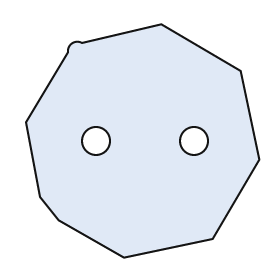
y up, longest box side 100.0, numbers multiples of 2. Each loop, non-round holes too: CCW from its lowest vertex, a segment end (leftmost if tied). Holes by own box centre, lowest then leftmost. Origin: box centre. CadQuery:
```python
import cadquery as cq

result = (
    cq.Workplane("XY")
    .moveTo(-8.0, -50.0)
    .lineTo(30.0, -42.0)
    .lineTo(50.0, -8.0)
    .lineTo(42.0, 30.0)
    .lineTo(8.0, 50.0)
    .lineTo(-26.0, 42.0)
    .threePointArc((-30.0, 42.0), (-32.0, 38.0))
    .lineTo(-50.0, 8.0)
    .lineTo(-44.0, -24.0)
    .lineTo(-36.0, -34.0)
    .close()
    .moveTo(-20.0, 0.0)
    .circle(6.0)
    .moveTo(22.0, 0.0)
    .circle(6.0)
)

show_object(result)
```